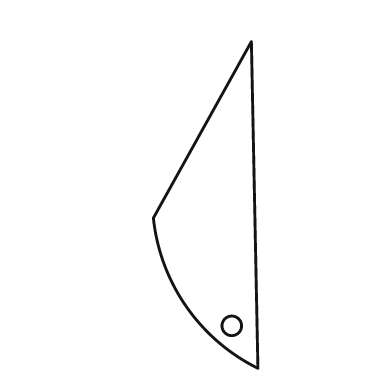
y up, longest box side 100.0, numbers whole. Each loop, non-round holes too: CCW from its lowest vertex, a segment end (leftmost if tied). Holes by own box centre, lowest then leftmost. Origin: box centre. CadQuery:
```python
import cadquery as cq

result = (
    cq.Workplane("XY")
    .moveTo(16.0, -50.0)
    .lineTo(14.0, 50.0)
    .lineTo(-16.0, -4.0)
    .threePointArc((-6.0, -31.0), (16.0, -50.0))
    .close()
    .moveTo(8.0, -37.0)
    .circle(3.0)
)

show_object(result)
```